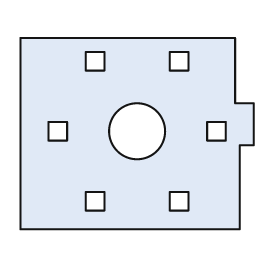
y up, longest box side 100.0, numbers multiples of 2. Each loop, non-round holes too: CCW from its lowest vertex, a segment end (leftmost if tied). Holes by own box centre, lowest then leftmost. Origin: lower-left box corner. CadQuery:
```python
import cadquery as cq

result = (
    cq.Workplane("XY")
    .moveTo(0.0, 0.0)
    .lineTo(94.0, 0.0)
    .lineTo(94.0, 36.0)
    .lineTo(100.0, 36.0)
    .lineTo(100.0, 54.0)
    .lineTo(92.0, 54.0)
    .lineTo(92.0, 82.0)
    .lineTo(0.0, 82.0)
    .close()
    .moveTo(28.0, 8.0)
    .lineTo(36.0, 8.0)
    .lineTo(36.0, 16.0)
    .lineTo(28.0, 16.0)
    .close()
    .moveTo(64.0, 8.0)
    .lineTo(72.0, 8.0)
    .lineTo(72.0, 16.0)
    .lineTo(64.0, 16.0)
    .close()
    .moveTo(12.0, 38.0)
    .lineTo(20.0, 38.0)
    .lineTo(20.0, 46.0)
    .lineTo(12.0, 46.0)
    .close()
    .moveTo(50.0, 42.0)
    .circle(12.0)
    .moveTo(80.0, 38.0)
    .lineTo(88.0, 38.0)
    .lineTo(88.0, 46.0)
    .lineTo(80.0, 46.0)
    .close()
    .moveTo(28.0, 68.0)
    .lineTo(36.0, 68.0)
    .lineTo(36.0, 76.0)
    .lineTo(28.0, 76.0)
    .close()
    .moveTo(64.0, 68.0)
    .lineTo(72.0, 68.0)
    .lineTo(72.0, 76.0)
    .lineTo(64.0, 76.0)
    .close()
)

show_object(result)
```